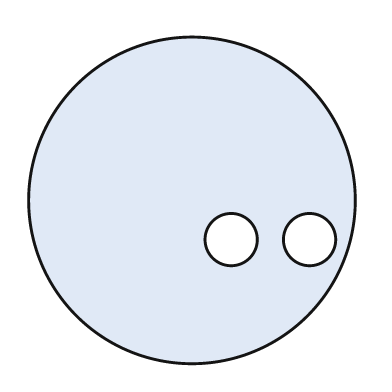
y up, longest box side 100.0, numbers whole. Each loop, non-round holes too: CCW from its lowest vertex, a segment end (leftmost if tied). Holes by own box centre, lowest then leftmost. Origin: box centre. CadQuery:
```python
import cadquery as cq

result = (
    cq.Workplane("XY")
    .moveTo(0.0, 0.0)
    .circle(50.0)
    .moveTo(12.0, -12.0)
    .circle(8.0)
    .moveTo(36.0, -12.0)
    .circle(8.0)
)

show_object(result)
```